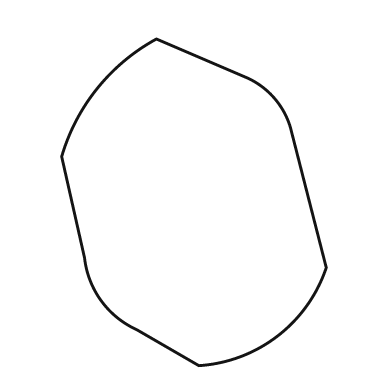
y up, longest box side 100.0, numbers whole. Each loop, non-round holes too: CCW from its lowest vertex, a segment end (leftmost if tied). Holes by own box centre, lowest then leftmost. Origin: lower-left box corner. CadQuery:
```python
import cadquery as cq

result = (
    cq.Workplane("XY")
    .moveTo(42.0, 0.0)
    .threePointArc((66.0, 9.0), (81.0, 30.0))
    .lineTo(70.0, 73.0)
    .threePointArc((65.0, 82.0), (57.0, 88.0))
    .lineTo(29.0, 100.0)
    .threePointArc((11.0, 85.0), (0.0, 64.0))
    .lineTo(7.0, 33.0)
    .threePointArc((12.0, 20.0), (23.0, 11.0))
    .close()
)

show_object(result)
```